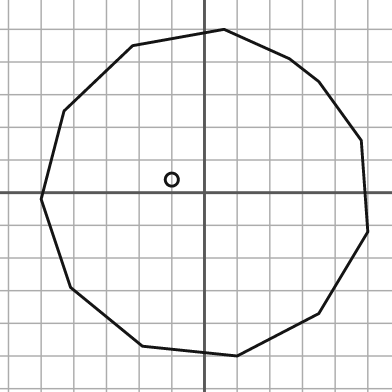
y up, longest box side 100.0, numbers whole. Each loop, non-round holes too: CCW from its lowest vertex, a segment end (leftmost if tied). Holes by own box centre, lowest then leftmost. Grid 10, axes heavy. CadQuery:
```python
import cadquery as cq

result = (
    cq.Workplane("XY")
    .moveTo(10.0, -50.0)
    .lineTo(35.0, -37.0)
    .lineTo(50.0, -12.0)
    .lineTo(48.0, 16.0)
    .lineTo(35.0, 34.0)
    .lineTo(26.0, 41.0)
    .lineTo(6.0, 50.0)
    .lineTo(-22.0, 45.0)
    .lineTo(-43.0, 25.0)
    .lineTo(-50.0, -2.0)
    .lineTo(-41.0, -29.0)
    .lineTo(-19.0, -47.0)
    .close()
    .moveTo(-10.0, 4.0)
    .circle(2.0)
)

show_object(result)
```